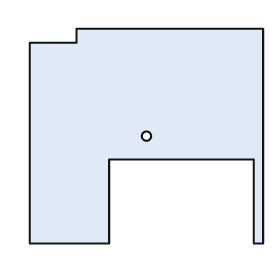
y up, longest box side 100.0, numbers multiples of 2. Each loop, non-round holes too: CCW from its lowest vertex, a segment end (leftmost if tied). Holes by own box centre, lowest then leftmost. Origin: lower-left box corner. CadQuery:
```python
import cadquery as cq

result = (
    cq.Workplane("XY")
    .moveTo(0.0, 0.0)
    .lineTo(34.0, 0.0)
    .lineTo(34.0, 36.0)
    .lineTo(96.0, 36.0)
    .lineTo(96.0, 0.0)
    .lineTo(100.0, 0.0)
    .lineTo(100.0, 92.0)
    .lineTo(20.0, 92.0)
    .lineTo(20.0, 86.0)
    .lineTo(0.0, 86.0)
    .close()
    .moveTo(50.0, 46.0)
    .circle(2.0)
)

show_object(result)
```